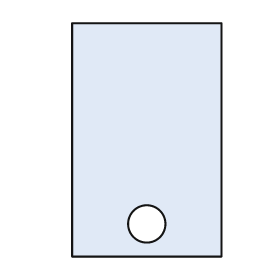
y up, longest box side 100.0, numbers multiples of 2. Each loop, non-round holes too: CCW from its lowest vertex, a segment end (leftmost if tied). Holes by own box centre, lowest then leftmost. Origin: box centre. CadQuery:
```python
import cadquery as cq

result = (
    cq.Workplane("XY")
    .moveTo(-32.0, -50.0)
    .lineTo(32.0, -50.0)
    .lineTo(32.0, 50.0)
    .lineTo(-32.0, 50.0)
    .close()
    .moveTo(0.0, -36.0)
    .circle(8.0)
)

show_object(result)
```